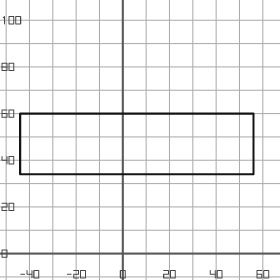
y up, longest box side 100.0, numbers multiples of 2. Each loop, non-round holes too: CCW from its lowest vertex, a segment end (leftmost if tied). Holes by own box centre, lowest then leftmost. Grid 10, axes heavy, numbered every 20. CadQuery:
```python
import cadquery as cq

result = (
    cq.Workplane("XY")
    .moveTo(-44.0, 34.0)
    .lineTo(56.0, 34.0)
    .lineTo(56.0, 60.0)
    .lineTo(-44.0, 60.0)
    .close()
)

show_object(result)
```